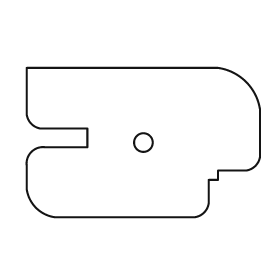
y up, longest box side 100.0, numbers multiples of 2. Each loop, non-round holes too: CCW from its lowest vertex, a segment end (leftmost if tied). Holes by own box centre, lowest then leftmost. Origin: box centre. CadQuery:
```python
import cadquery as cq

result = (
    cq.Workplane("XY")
    .moveTo(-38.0, -32.0)
    .lineTo(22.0, -32.0)
    .threePointArc((26.0, -30.0), (28.0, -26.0))
    .lineTo(28.0, -16.0)
    .lineTo(32.0, -16.0)
    .lineTo(32.0, -12.0)
    .lineTo(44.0, -12.0)
    .threePointArc((48.0, -10.0), (50.0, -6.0))
    .lineTo(50.0, 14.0)
    .threePointArc((44.0, 26.0), (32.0, 32.0))
    .lineTo(-50.0, 32.0)
    .lineTo(-50.0, 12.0)
    .threePointArc((-48.0, 8.0), (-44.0, 6.0))
    .lineTo(-24.0, 6.0)
    .lineTo(-24.0, -2.0)
    .lineTo(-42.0, -2.0)
    .threePointArc((-48.0, -4.0), (-50.0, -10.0))
    .lineTo(-50.0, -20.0)
    .threePointArc((-46.0, -28.0), (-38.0, -32.0))
    .close()
    .moveTo(0.0, 0.0)
    .circle(4.0)
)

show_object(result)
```